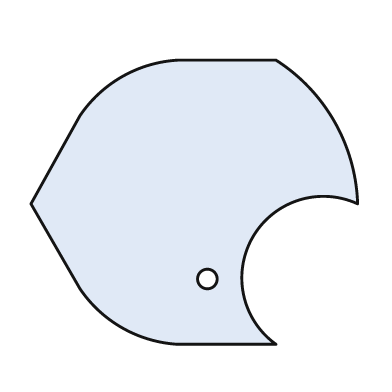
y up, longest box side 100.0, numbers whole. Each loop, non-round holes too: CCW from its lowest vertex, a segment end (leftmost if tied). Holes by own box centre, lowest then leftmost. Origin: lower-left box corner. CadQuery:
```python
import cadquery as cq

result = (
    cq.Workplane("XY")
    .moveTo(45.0, 0.0)
    .lineTo(75.0, 0.0)
    .threePointArc((68.0, 33.0), (100.0, 43.0))
    .threePointArc((93.0, 68.0), (75.0, 87.0))
    .lineTo(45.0, 87.0)
    .threePointArc((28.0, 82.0), (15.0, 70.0))
    .lineTo(0.0, 43.0)
    .lineTo(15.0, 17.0)
    .threePointArc((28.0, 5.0), (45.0, 0.0))
    .close()
    .moveTo(54.0, 20.0)
    .circle(3.0)
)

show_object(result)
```